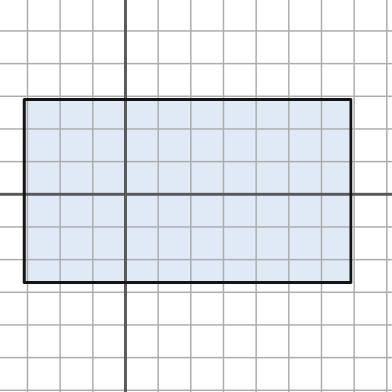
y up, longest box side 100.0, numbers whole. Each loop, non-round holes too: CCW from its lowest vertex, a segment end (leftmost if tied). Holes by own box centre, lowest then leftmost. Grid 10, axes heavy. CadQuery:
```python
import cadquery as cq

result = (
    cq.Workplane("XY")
    .moveTo(-31.0, -27.0)
    .lineTo(69.0, -27.0)
    .lineTo(69.0, 29.0)
    .lineTo(-31.0, 29.0)
    .close()
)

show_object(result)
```